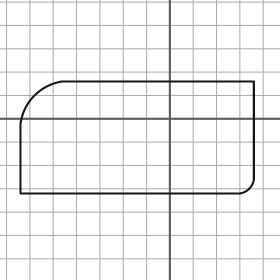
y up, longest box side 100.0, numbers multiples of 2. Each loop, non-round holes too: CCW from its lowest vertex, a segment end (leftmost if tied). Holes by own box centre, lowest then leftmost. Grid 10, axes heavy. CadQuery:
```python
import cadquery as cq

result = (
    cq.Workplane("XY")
    .moveTo(-64.0, -32.0)
    .lineTo(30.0, -32.0)
    .threePointArc((34.0, -30.0), (36.0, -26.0))
    .lineTo(36.0, 16.0)
    .lineTo(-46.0, 16.0)
    .threePointArc((-58.0, 10.0), (-64.0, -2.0))
    .close()
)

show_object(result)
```